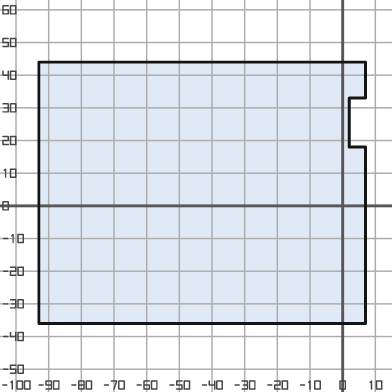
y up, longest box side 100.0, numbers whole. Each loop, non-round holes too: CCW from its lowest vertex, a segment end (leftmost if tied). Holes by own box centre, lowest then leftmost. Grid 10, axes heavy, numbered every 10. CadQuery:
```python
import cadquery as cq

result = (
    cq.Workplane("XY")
    .moveTo(-93.0, -36.0)
    .lineTo(7.0, -36.0)
    .lineTo(7.0, 18.0)
    .lineTo(2.0, 18.0)
    .lineTo(2.0, 33.0)
    .lineTo(7.0, 33.0)
    .lineTo(7.0, 44.0)
    .lineTo(-93.0, 44.0)
    .close()
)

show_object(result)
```